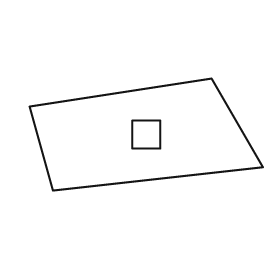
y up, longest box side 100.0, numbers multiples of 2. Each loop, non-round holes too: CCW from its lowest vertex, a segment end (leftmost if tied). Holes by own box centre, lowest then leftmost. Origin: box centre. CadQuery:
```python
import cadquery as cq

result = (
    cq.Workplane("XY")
    .moveTo(-40.0, -24.0)
    .lineTo(50.0, -14.0)
    .lineTo(28.0, 24.0)
    .lineTo(-50.0, 12.0)
    .close()
    .moveTo(-6.0, -6.0)
    .lineTo(6.0, -6.0)
    .lineTo(6.0, 6.0)
    .lineTo(-6.0, 6.0)
    .close()
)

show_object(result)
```